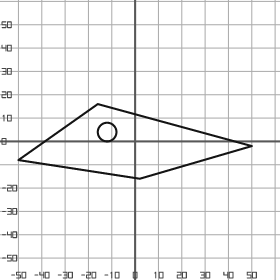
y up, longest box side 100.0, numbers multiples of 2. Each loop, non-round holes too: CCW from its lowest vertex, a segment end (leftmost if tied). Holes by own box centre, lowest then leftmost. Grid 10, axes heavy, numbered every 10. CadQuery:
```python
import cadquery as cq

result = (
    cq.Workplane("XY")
    .moveTo(2.0, -16.0)
    .lineTo(50.0, -2.0)
    .lineTo(-16.0, 16.0)
    .lineTo(-50.0, -8.0)
    .close()
    .moveTo(-12.0, 4.0)
    .circle(4.0)
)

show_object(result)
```